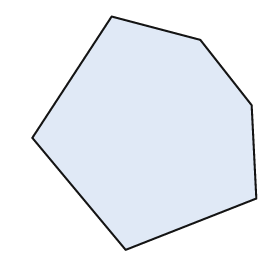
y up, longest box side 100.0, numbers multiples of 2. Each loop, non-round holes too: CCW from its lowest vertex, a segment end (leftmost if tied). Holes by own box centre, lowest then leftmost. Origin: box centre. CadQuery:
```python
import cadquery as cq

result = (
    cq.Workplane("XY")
    .moveTo(-8.0, -50.0)
    .lineTo(48.0, -28.0)
    .lineTo(46.0, 12.0)
    .lineTo(24.0, 40.0)
    .lineTo(-14.0, 50.0)
    .lineTo(-48.0, -2.0)
    .close()
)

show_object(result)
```